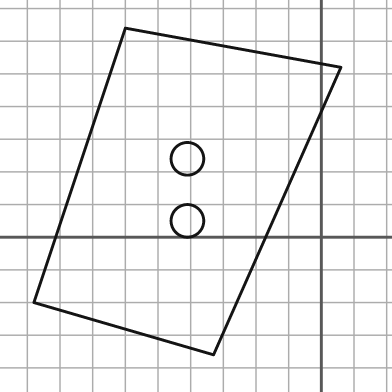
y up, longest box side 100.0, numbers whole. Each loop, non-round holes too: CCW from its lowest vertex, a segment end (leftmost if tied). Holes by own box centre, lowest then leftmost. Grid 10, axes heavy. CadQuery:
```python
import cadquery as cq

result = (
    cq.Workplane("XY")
    .moveTo(-33.0, -36.0)
    .lineTo(6.0, 52.0)
    .lineTo(-60.0, 64.0)
    .lineTo(-88.0, -20.0)
    .close()
    .moveTo(-41.0, 5.0)
    .circle(5.0)
    .moveTo(-41.0, 24.0)
    .circle(5.0)
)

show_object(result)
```